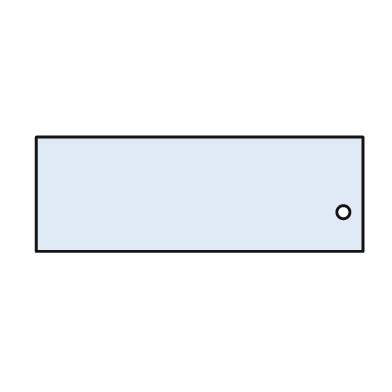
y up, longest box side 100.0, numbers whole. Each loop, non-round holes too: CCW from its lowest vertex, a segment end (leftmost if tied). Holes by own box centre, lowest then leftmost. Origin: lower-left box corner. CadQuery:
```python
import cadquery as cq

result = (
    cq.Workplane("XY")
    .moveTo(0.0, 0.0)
    .lineTo(100.0, 0.0)
    .lineTo(100.0, 35.0)
    .lineTo(0.0, 35.0)
    .close()
    .moveTo(94.0, 12.0)
    .circle(2.0)
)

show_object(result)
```